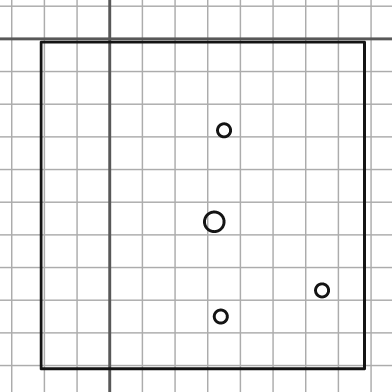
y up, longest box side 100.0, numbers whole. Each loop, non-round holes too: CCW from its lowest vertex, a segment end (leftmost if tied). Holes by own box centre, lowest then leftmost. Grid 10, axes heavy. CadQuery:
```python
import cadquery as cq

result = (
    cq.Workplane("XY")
    .moveTo(-21.0, -101.0)
    .lineTo(78.0, -101.0)
    .lineTo(78.0, -1.0)
    .lineTo(-21.0, -1.0)
    .close()
    .moveTo(34.0, -85.0)
    .circle(2.0)
    .moveTo(65.0, -77.0)
    .circle(2.0)
    .moveTo(32.0, -56.0)
    .circle(3.0)
    .moveTo(35.0, -28.0)
    .circle(2.0)
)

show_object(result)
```